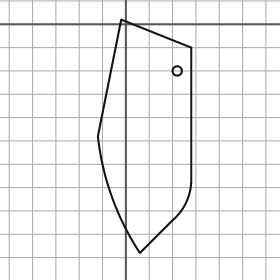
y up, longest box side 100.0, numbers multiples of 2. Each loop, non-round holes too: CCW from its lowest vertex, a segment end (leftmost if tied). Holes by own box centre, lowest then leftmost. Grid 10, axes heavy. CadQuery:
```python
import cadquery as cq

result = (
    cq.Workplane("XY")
    .moveTo(6.0, -98.0)
    .lineTo(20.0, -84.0)
    .threePointArc((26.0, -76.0), (28.0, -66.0))
    .lineTo(28.0, -10.0)
    .lineTo(-2.0, 2.0)
    .lineTo(-12.0, -48.0)
    .threePointArc((-6.0, -74.0), (6.0, -98.0))
    .close()
    .moveTo(22.0, -20.0)
    .circle(2.0)
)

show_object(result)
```